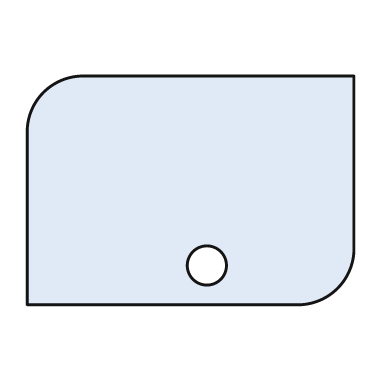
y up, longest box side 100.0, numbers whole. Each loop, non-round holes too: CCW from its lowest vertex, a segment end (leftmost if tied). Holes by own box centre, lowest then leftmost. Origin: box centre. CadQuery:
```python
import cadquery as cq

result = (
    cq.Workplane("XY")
    .moveTo(-50.0, -35.0)
    .lineTo(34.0, -35.0)
    .threePointArc((45.0, -30.0), (50.0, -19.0))
    .lineTo(50.0, 35.0)
    .lineTo(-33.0, 35.0)
    .threePointArc((-45.0, 30.0), (-50.0, 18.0))
    .close()
    .moveTo(5.0, -23.0)
    .circle(6.0)
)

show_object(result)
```